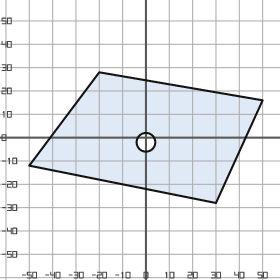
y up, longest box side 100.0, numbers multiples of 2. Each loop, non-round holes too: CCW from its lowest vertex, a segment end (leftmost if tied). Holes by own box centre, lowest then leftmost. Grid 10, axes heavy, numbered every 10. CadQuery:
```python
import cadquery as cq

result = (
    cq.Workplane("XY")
    .moveTo(30.0, -28.0)
    .lineTo(50.0, 16.0)
    .lineTo(-20.0, 28.0)
    .lineTo(-50.0, -12.0)
    .close()
    .moveTo(0.0, -2.0)
    .circle(4.0)
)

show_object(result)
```